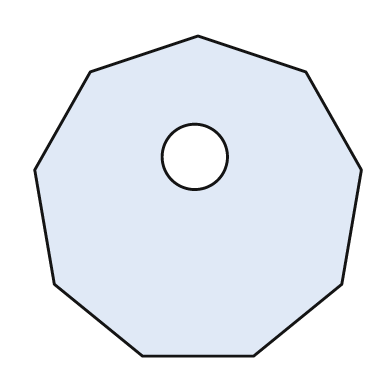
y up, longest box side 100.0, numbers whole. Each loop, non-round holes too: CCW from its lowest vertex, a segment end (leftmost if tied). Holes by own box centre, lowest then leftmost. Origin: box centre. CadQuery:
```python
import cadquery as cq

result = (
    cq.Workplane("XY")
    .moveTo(-17.0, -49.0)
    .lineTo(17.0, -49.0)
    .lineTo(44.0, -27.0)
    .lineTo(50.0, 8.0)
    .lineTo(33.0, 38.0)
    .lineTo(0.0, 49.0)
    .lineTo(-33.0, 38.0)
    .lineTo(-50.0, 8.0)
    .lineTo(-44.0, -27.0)
    .close()
    .moveTo(-1.0, 12.0)
    .circle(10.0)
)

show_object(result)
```